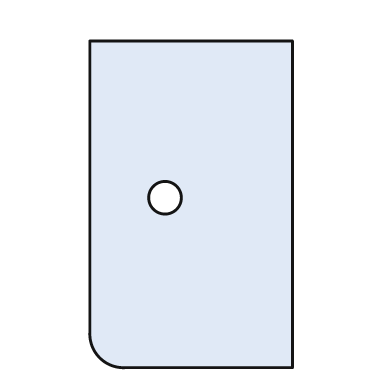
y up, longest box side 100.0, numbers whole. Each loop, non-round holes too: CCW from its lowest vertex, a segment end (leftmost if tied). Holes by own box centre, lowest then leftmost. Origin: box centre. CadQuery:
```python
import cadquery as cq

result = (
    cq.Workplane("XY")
    .moveTo(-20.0, -50.0)
    .lineTo(31.0, -50.0)
    .lineTo(31.0, 50.0)
    .lineTo(-31.0, 50.0)
    .lineTo(-31.0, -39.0)
    .threePointArc((-28.0, -47.0), (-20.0, -50.0))
    .close()
    .moveTo(-8.0, 2.0)
    .circle(5.0)
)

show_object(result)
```